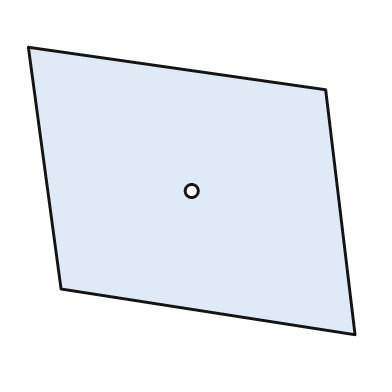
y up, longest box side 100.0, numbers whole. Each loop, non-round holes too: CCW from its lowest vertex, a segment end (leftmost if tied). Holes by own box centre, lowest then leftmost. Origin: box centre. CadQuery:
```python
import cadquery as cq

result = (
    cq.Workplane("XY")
    .moveTo(50.0, -44.0)
    .lineTo(41.0, 31.0)
    .lineTo(-50.0, 44.0)
    .lineTo(-40.0, -30.0)
    .close()
    .moveTo(0.0, 0.0)
    .circle(2.0)
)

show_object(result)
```